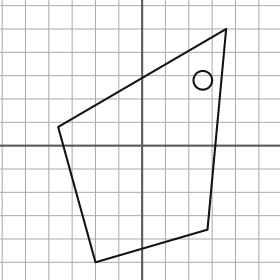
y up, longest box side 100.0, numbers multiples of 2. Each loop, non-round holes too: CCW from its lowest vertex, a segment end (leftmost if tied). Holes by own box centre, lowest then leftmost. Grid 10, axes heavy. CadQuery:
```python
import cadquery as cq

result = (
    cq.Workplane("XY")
    .moveTo(-20.0, -50.0)
    .lineTo(28.0, -36.0)
    .lineTo(36.0, 50.0)
    .lineTo(-36.0, 8.0)
    .close()
    .moveTo(26.0, 28.0)
    .circle(4.0)
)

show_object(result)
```